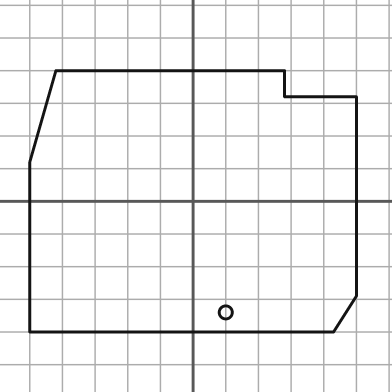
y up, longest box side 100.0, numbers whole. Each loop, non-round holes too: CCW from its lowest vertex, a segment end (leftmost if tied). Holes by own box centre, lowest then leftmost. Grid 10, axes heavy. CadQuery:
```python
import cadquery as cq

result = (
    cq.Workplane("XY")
    .moveTo(-50.0, -40.0)
    .lineTo(43.0, -40.0)
    .lineTo(50.0, -29.0)
    .lineTo(50.0, 32.0)
    .lineTo(28.0, 32.0)
    .lineTo(28.0, 40.0)
    .lineTo(-42.0, 40.0)
    .lineTo(-50.0, 12.0)
    .close()
    .moveTo(10.0, -34.0)
    .circle(2.0)
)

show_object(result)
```